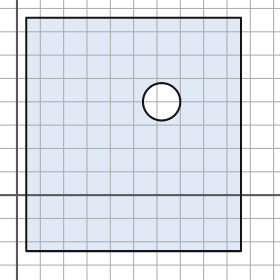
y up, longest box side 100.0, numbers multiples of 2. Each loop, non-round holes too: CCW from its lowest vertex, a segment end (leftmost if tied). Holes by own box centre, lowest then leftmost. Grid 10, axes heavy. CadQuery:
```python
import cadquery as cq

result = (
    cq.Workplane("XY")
    .moveTo(4.0, -24.0)
    .lineTo(96.0, -24.0)
    .lineTo(96.0, 76.0)
    .lineTo(4.0, 76.0)
    .close()
    .moveTo(62.0, 40.0)
    .circle(8.0)
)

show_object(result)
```